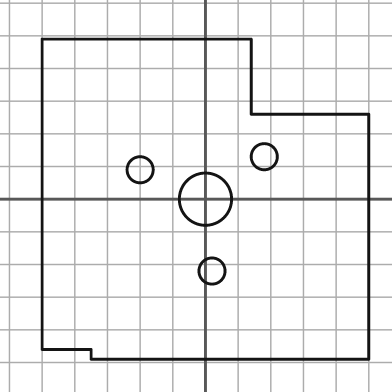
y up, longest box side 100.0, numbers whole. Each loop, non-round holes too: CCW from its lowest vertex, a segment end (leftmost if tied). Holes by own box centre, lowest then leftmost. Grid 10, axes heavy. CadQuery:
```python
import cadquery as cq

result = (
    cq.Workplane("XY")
    .moveTo(-35.0, -49.0)
    .lineTo(50.0, -49.0)
    .lineTo(50.0, 26.0)
    .lineTo(14.0, 26.0)
    .lineTo(14.0, 49.0)
    .lineTo(-50.0, 49.0)
    .lineTo(-50.0, -46.0)
    .lineTo(-35.0, -46.0)
    .close()
    .moveTo(2.0, -22.0)
    .circle(4.0)
    .moveTo(0.0, 0.0)
    .circle(8.0)
    .moveTo(-20.0, 9.0)
    .circle(4.0)
    .moveTo(18.0, 13.0)
    .circle(4.0)
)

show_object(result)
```